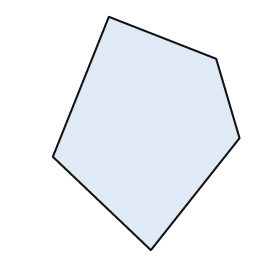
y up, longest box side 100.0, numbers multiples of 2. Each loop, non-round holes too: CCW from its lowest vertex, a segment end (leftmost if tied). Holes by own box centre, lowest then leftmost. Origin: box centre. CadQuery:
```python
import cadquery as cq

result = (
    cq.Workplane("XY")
    .moveTo(2.0, -50.0)
    .lineTo(40.0, -2.0)
    .lineTo(30.0, 32.0)
    .lineTo(-16.0, 50.0)
    .lineTo(-40.0, -10.0)
    .close()
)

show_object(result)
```